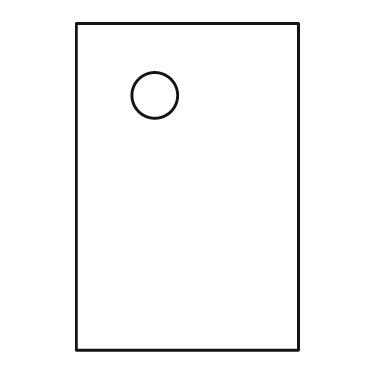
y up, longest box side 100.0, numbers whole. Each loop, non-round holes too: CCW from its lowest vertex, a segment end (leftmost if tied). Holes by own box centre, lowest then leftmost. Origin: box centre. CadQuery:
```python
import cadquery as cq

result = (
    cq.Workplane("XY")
    .moveTo(-34.0, -50.0)
    .lineTo(34.0, -50.0)
    .lineTo(34.0, 50.0)
    .lineTo(-34.0, 50.0)
    .close()
    .moveTo(-10.0, 28.0)
    .circle(7.0)
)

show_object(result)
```